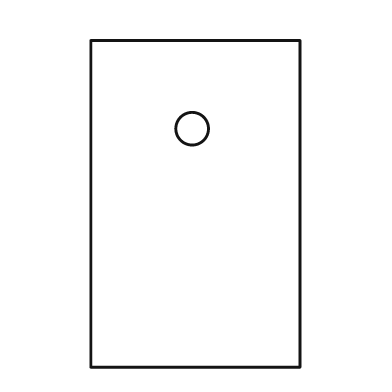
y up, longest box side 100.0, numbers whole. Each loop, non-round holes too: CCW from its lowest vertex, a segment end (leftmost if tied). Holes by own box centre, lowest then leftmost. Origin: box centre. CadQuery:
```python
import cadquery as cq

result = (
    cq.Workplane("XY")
    .moveTo(-32.0, -50.0)
    .lineTo(32.0, -50.0)
    .lineTo(32.0, 50.0)
    .lineTo(-32.0, 50.0)
    .close()
    .moveTo(-1.0, 23.0)
    .circle(5.0)
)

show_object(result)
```